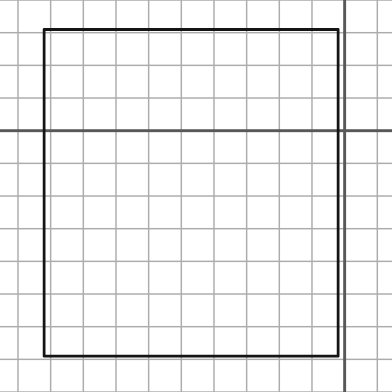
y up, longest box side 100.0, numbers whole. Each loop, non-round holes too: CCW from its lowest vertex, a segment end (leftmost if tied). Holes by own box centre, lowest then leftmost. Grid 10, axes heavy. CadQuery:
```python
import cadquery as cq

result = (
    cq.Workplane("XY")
    .moveTo(-92.0, -69.0)
    .lineTo(-2.0, -69.0)
    .lineTo(-2.0, 31.0)
    .lineTo(-92.0, 31.0)
    .close()
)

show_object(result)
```